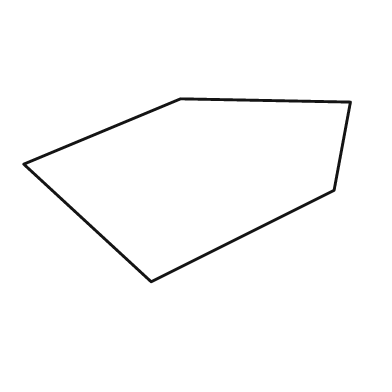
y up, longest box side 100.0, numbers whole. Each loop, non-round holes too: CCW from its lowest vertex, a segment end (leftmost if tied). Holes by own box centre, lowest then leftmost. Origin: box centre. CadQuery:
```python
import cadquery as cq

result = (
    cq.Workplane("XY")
    .moveTo(-11.0, -28.0)
    .lineTo(45.0, 0.0)
    .lineTo(50.0, 27.0)
    .lineTo(-2.0, 28.0)
    .lineTo(-50.0, 8.0)
    .close()
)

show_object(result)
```